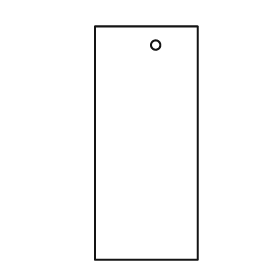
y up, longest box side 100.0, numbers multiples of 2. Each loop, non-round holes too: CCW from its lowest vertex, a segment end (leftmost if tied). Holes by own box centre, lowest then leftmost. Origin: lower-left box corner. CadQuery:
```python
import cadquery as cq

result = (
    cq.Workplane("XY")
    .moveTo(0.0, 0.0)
    .lineTo(44.0, 0.0)
    .lineTo(44.0, 100.0)
    .lineTo(0.0, 100.0)
    .close()
    .moveTo(26.0, 92.0)
    .circle(2.0)
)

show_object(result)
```